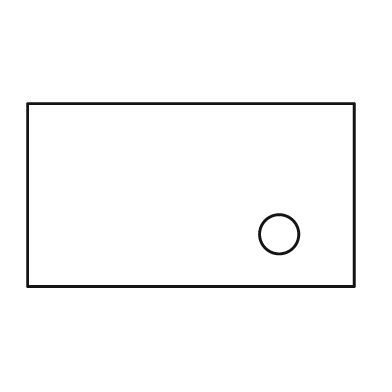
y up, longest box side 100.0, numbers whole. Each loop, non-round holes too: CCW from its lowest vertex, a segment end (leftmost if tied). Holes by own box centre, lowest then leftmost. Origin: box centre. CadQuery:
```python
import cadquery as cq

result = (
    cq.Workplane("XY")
    .moveTo(-50.0, -28.0)
    .lineTo(50.0, -28.0)
    .lineTo(50.0, 28.0)
    .lineTo(-50.0, 28.0)
    .close()
    .moveTo(27.0, -12.0)
    .circle(6.0)
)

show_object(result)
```